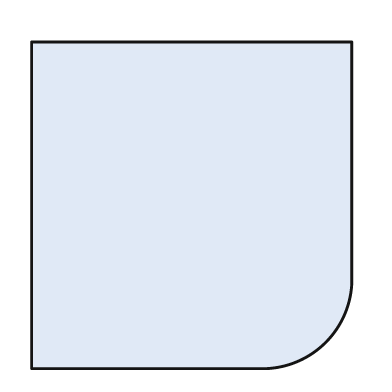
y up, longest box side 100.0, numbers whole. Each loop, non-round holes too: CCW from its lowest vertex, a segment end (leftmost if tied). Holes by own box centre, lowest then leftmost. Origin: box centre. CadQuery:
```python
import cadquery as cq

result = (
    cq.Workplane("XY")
    .moveTo(-49.0, -50.0)
    .lineTo(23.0, -50.0)
    .threePointArc((41.0, -42.0), (49.0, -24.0))
    .lineTo(49.0, 50.0)
    .lineTo(-49.0, 50.0)
    .close()
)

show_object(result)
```